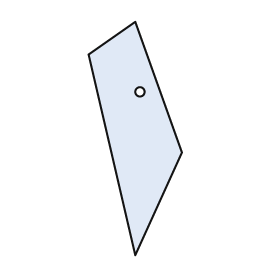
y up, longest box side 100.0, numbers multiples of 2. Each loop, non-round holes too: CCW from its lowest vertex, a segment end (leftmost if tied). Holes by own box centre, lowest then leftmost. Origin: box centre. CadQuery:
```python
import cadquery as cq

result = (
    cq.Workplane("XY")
    .moveTo(0.0, -50.0)
    .lineTo(20.0, -6.0)
    .lineTo(0.0, 50.0)
    .lineTo(-20.0, 36.0)
    .close()
    .moveTo(2.0, 20.0)
    .circle(2.0)
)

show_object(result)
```